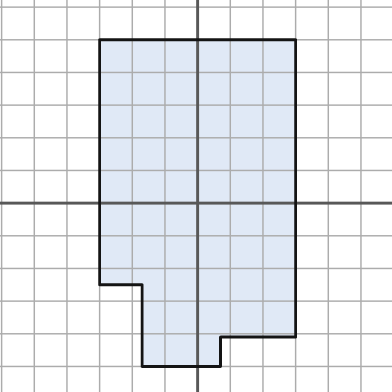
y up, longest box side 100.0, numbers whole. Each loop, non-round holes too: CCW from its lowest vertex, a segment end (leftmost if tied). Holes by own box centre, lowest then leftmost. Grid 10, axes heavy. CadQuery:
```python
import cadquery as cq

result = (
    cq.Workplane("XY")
    .moveTo(-17.0, -50.0)
    .lineTo(7.0, -50.0)
    .lineTo(7.0, -41.0)
    .lineTo(30.0, -41.0)
    .lineTo(30.0, 50.0)
    .lineTo(-30.0, 50.0)
    .lineTo(-30.0, -25.0)
    .lineTo(-17.0, -25.0)
    .close()
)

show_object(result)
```